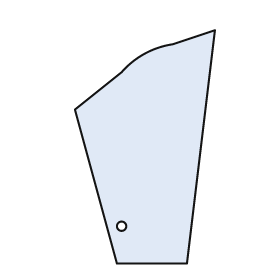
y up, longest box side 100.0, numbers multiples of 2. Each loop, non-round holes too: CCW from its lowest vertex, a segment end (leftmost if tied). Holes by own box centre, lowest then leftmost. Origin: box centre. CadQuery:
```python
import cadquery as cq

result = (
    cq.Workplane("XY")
    .moveTo(-12.0, -50.0)
    .lineTo(18.0, -50.0)
    .lineTo(30.0, 50.0)
    .lineTo(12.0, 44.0)
    .threePointArc((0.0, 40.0), (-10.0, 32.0))
    .lineTo(-30.0, 16.0)
    .close()
    .moveTo(-10.0, -34.0)
    .circle(2.0)
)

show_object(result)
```